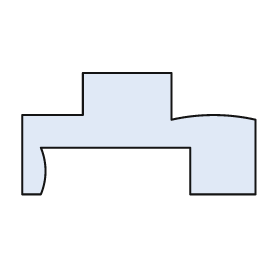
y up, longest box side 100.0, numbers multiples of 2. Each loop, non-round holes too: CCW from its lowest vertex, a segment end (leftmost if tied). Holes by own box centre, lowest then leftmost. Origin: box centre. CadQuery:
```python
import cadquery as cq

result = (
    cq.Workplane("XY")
    .moveTo(-50.0, -26.0)
    .lineTo(-42.0, -26.0)
    .threePointArc((-40.0, -16.0), (-42.0, -6.0))
    .lineTo(22.0, -6.0)
    .lineTo(22.0, -26.0)
    .lineTo(50.0, -26.0)
    .lineTo(50.0, 6.0)
    .threePointArc((32.0, 8.0), (14.0, 6.0))
    .lineTo(14.0, 26.0)
    .lineTo(-24.0, 26.0)
    .lineTo(-24.0, 8.0)
    .lineTo(-50.0, 8.0)
    .close()
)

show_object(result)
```